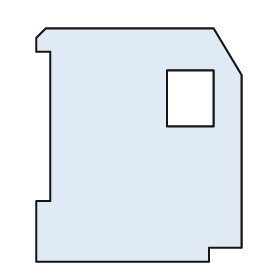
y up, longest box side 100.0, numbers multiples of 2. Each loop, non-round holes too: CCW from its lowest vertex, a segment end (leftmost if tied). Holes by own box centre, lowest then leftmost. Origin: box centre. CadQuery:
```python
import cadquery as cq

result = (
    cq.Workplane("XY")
    .moveTo(-44.0, -50.0)
    .lineTo(30.0, -50.0)
    .lineTo(30.0, -44.0)
    .lineTo(44.0, -44.0)
    .lineTo(44.0, 30.0)
    .lineTo(32.0, 50.0)
    .lineTo(-40.0, 50.0)
    .lineTo(-44.0, 46.0)
    .lineTo(-44.0, 40.0)
    .lineTo(-38.0, 40.0)
    .lineTo(-38.0, -24.0)
    .lineTo(-44.0, -24.0)
    .close()
    .moveTo(12.0, 8.0)
    .lineTo(32.0, 8.0)
    .lineTo(32.0, 32.0)
    .lineTo(12.0, 32.0)
    .close()
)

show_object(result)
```